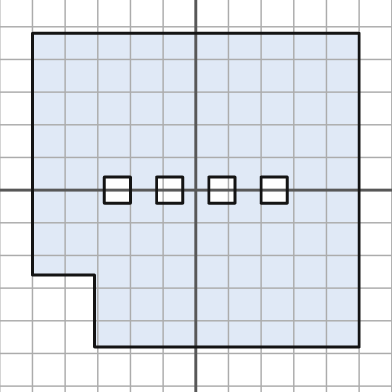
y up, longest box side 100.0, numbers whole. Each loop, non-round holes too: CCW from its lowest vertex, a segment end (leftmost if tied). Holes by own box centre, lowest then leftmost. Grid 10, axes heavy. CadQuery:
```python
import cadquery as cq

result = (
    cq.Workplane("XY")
    .moveTo(-31.0, -48.0)
    .lineTo(50.0, -48.0)
    .lineTo(50.0, 48.0)
    .lineTo(-50.0, 48.0)
    .lineTo(-50.0, -26.0)
    .lineTo(-31.0, -26.0)
    .close()
    .moveTo(-28.0, -4.0)
    .lineTo(-20.0, -4.0)
    .lineTo(-20.0, 4.0)
    .lineTo(-28.0, 4.0)
    .close()
    .moveTo(-12.0, -4.0)
    .lineTo(-4.0, -4.0)
    .lineTo(-4.0, 4.0)
    .lineTo(-12.0, 4.0)
    .close()
    .moveTo(4.0, -4.0)
    .lineTo(12.0, -4.0)
    .lineTo(12.0, 4.0)
    .lineTo(4.0, 4.0)
    .close()
    .moveTo(20.0, -4.0)
    .lineTo(28.0, -4.0)
    .lineTo(28.0, 4.0)
    .lineTo(20.0, 4.0)
    .close()
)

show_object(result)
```